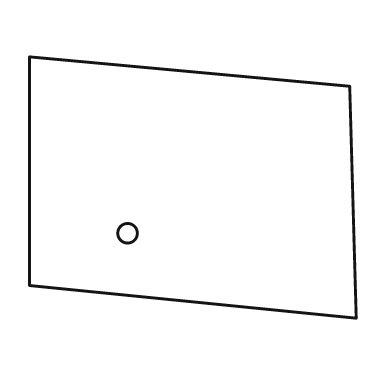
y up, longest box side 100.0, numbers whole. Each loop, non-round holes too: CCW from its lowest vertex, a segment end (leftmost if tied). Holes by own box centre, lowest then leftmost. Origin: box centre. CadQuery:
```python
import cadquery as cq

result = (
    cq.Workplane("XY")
    .moveTo(50.0, -40.0)
    .lineTo(48.0, 31.0)
    .lineTo(-50.0, 40.0)
    .lineTo(-50.0, -30.0)
    .close()
    .moveTo(-20.0, -14.0)
    .circle(3.0)
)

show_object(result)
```